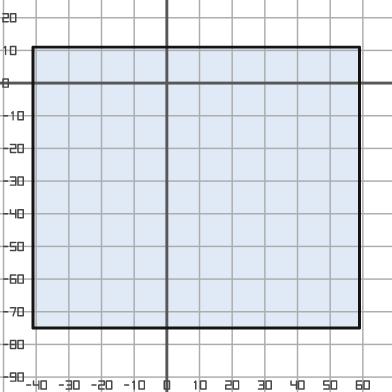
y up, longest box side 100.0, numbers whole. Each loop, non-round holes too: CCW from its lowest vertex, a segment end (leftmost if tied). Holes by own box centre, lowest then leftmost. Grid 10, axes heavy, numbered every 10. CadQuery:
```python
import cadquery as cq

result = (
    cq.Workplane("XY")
    .moveTo(-41.0, -75.0)
    .lineTo(59.0, -75.0)
    .lineTo(59.0, 11.0)
    .lineTo(-41.0, 11.0)
    .close()
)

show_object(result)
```